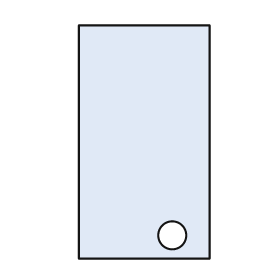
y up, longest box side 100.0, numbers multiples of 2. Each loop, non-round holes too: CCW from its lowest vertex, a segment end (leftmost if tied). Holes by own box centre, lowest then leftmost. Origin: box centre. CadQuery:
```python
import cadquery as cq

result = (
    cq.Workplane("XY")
    .moveTo(-28.0, -50.0)
    .lineTo(28.0, -50.0)
    .lineTo(28.0, 50.0)
    .lineTo(-28.0, 50.0)
    .close()
    .moveTo(12.0, -40.0)
    .circle(6.0)
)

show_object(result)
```